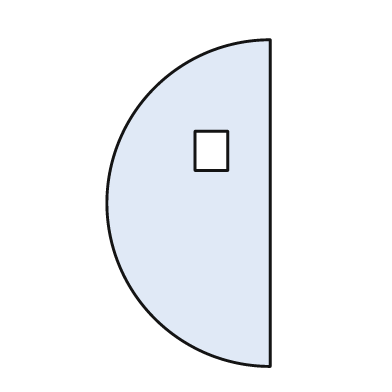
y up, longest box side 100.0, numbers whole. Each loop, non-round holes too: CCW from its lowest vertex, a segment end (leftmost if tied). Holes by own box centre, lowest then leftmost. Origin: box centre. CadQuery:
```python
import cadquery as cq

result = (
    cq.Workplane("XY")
    .moveTo(25.0, -50.0)
    .lineTo(25.0, 50.0)
    .threePointArc((-25.0, 0.0), (25.0, -50.0))
    .close()
    .moveTo(2.0, 10.0)
    .lineTo(12.0, 10.0)
    .lineTo(12.0, 22.0)
    .lineTo(2.0, 22.0)
    .close()
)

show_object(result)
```